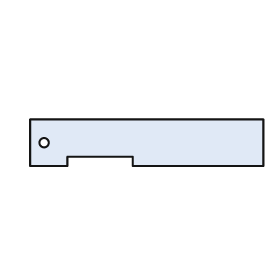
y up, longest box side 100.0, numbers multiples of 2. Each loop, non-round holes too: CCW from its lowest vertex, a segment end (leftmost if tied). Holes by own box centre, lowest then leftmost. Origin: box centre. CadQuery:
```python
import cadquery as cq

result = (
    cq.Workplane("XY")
    .moveTo(-50.0, -10.0)
    .lineTo(-34.0, -10.0)
    .lineTo(-34.0, -6.0)
    .lineTo(-6.0, -6.0)
    .lineTo(-6.0, -10.0)
    .lineTo(50.0, -10.0)
    .lineTo(50.0, 10.0)
    .lineTo(-50.0, 10.0)
    .close()
    .moveTo(-44.0, 0.0)
    .circle(2.0)
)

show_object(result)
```